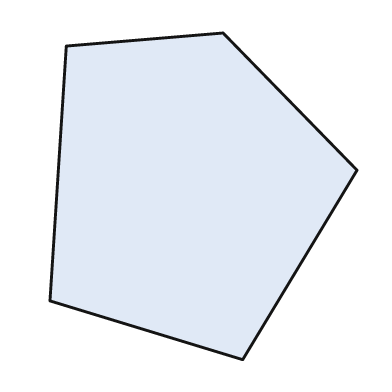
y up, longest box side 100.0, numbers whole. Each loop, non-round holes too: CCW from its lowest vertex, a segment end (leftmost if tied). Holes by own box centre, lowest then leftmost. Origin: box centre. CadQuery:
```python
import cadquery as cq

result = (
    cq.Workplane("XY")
    .moveTo(12.0, -50.0)
    .lineTo(47.0, 8.0)
    .lineTo(6.0, 50.0)
    .lineTo(-42.0, 46.0)
    .lineTo(-47.0, -32.0)
    .close()
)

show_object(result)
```